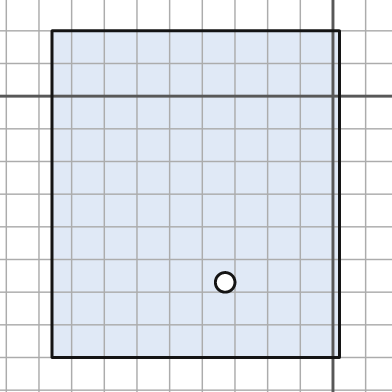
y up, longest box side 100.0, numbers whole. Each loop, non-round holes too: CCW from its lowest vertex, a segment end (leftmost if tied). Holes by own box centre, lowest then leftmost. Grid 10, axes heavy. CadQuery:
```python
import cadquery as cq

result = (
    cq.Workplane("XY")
    .moveTo(-86.0, -80.0)
    .lineTo(2.0, -80.0)
    .lineTo(2.0, 20.0)
    .lineTo(-86.0, 20.0)
    .close()
    .moveTo(-33.0, -57.0)
    .circle(3.0)
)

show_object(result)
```